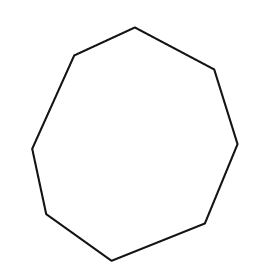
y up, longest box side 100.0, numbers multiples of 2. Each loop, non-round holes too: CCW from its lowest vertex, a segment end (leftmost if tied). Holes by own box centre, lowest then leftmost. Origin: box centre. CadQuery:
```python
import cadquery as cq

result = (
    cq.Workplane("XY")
    .moveTo(-10.0, -50.0)
    .lineTo(30.0, -34.0)
    .lineTo(44.0, 0.0)
    .lineTo(34.0, 32.0)
    .lineTo(0.0, 50.0)
    .lineTo(-26.0, 38.0)
    .lineTo(-44.0, -2.0)
    .lineTo(-38.0, -30.0)
    .close()
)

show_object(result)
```